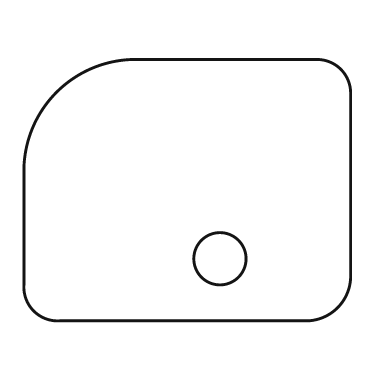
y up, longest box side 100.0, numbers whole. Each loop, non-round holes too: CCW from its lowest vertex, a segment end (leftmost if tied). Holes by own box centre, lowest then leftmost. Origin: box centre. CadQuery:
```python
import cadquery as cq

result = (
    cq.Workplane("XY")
    .moveTo(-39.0, -40.0)
    .lineTo(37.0, -40.0)
    .threePointArc((46.0, -36.0), (50.0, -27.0))
    .lineTo(50.0, 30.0)
    .threePointArc((47.0, 37.0), (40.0, 40.0))
    .lineTo(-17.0, 40.0)
    .threePointArc((-40.0, 30.0), (-50.0, 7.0))
    .lineTo(-50.0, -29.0)
    .threePointArc((-47.0, -37.0), (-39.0, -40.0))
    .close()
    .moveTo(10.0, -21.0)
    .circle(8.0)
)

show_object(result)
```